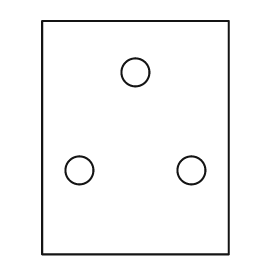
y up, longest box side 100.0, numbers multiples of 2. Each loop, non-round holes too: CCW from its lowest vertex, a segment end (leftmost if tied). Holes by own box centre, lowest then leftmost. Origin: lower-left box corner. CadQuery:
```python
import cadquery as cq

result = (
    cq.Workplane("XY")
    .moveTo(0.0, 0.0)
    .lineTo(80.0, 0.0)
    .lineTo(80.0, 100.0)
    .lineTo(0.0, 100.0)
    .close()
    .moveTo(16.0, 36.0)
    .circle(6.0)
    .moveTo(64.0, 36.0)
    .circle(6.0)
    .moveTo(40.0, 78.0)
    .circle(6.0)
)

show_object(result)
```